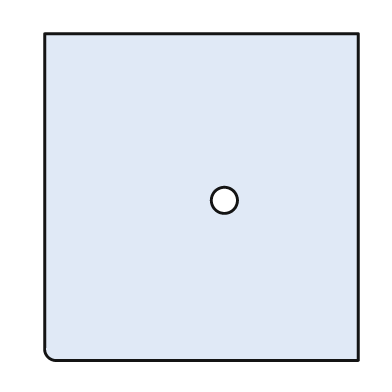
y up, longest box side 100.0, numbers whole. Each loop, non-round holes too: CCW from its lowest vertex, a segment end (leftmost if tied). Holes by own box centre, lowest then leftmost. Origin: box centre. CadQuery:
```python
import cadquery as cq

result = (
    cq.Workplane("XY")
    .moveTo(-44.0, -50.0)
    .lineTo(48.0, -50.0)
    .lineTo(48.0, 50.0)
    .lineTo(-48.0, 50.0)
    .lineTo(-48.0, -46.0)
    .threePointArc((-47.0, -49.0), (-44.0, -50.0))
    .close()
    .moveTo(7.0, -1.0)
    .circle(4.0)
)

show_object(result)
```